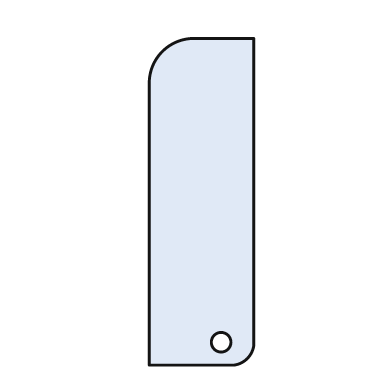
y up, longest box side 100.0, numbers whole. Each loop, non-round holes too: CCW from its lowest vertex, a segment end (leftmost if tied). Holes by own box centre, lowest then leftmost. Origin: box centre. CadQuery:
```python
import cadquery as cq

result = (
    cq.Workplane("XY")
    .moveTo(-16.0, -50.0)
    .lineTo(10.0, -50.0)
    .threePointArc((14.0, -48.0), (16.0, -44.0))
    .lineTo(16.0, 50.0)
    .lineTo(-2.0, 50.0)
    .threePointArc((-12.0, 46.0), (-16.0, 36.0))
    .close()
    .moveTo(6.0, -43.0)
    .circle(3.0)
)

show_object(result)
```